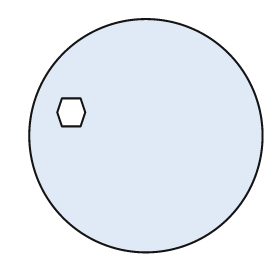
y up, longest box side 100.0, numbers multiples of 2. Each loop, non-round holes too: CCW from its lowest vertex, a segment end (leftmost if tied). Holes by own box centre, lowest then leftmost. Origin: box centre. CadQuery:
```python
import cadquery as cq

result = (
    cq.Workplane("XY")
    .moveTo(0.0, 0.0)
    .circle(50.0)
    .moveTo(-36.0, 4.0)
    .lineTo(-28.0, 4.0)
    .lineTo(-26.0, 10.0)
    .lineTo(-28.0, 16.0)
    .lineTo(-36.0, 16.0)
    .lineTo(-38.0, 10.0)
    .close()
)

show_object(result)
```